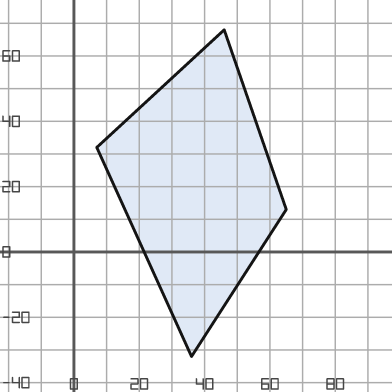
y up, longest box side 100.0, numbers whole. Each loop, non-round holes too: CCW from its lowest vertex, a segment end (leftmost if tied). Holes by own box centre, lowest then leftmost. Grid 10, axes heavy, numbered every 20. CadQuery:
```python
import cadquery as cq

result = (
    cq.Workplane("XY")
    .moveTo(36.0, -32.0)
    .lineTo(65.0, 13.0)
    .lineTo(46.0, 68.0)
    .lineTo(7.0, 32.0)
    .close()
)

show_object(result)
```